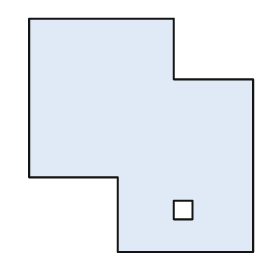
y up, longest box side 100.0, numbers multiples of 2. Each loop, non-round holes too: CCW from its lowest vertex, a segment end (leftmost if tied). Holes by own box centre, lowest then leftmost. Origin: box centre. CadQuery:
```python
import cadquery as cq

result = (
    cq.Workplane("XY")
    .moveTo(-10.0, -50.0)
    .lineTo(48.0, -50.0)
    .lineTo(48.0, 24.0)
    .lineTo(14.0, 24.0)
    .lineTo(14.0, 50.0)
    .lineTo(-48.0, 50.0)
    .lineTo(-48.0, -18.0)
    .lineTo(-10.0, -18.0)
    .close()
    .moveTo(14.0, -36.0)
    .lineTo(22.0, -36.0)
    .lineTo(22.0, -28.0)
    .lineTo(14.0, -28.0)
    .close()
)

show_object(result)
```